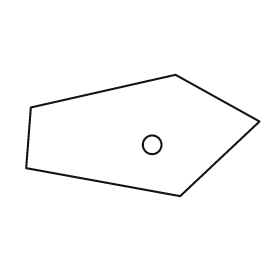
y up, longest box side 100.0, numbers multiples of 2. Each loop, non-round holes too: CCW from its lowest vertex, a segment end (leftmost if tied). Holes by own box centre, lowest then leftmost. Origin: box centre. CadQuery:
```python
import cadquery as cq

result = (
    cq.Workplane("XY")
    .moveTo(16.0, -26.0)
    .lineTo(50.0, 6.0)
    .lineTo(14.0, 26.0)
    .lineTo(-48.0, 12.0)
    .lineTo(-50.0, -14.0)
    .close()
    .moveTo(4.0, -4.0)
    .circle(4.0)
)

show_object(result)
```